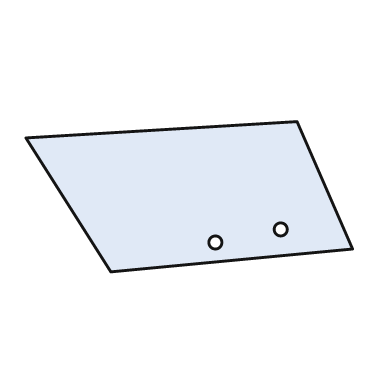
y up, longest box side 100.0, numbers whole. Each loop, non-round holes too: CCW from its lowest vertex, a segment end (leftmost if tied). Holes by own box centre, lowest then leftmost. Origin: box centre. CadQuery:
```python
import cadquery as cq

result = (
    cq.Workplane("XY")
    .moveTo(-24.0, -23.0)
    .lineTo(50.0, -16.0)
    .lineTo(33.0, 23.0)
    .lineTo(-50.0, 18.0)
    .close()
    .moveTo(8.0, -14.0)
    .circle(2.0)
    .moveTo(28.0, -10.0)
    .circle(2.0)
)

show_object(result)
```